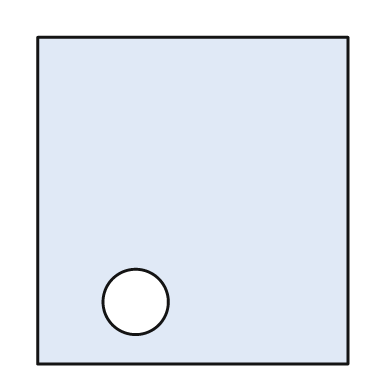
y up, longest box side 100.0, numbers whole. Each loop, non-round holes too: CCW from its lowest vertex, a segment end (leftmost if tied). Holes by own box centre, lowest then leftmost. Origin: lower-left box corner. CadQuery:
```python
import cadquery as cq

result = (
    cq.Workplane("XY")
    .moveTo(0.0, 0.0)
    .lineTo(95.0, 0.0)
    .lineTo(95.0, 100.0)
    .lineTo(0.0, 100.0)
    .close()
    .moveTo(30.0, 19.0)
    .circle(10.0)
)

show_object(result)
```